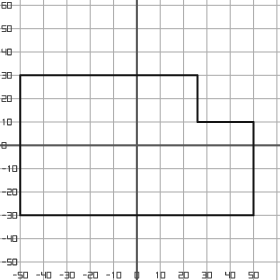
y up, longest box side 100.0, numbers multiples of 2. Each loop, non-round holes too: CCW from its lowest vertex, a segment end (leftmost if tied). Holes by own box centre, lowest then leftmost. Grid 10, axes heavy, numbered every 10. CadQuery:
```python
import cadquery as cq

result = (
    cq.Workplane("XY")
    .moveTo(-50.0, -30.0)
    .lineTo(50.0, -30.0)
    .lineTo(50.0, 10.0)
    .lineTo(26.0, 10.0)
    .lineTo(26.0, 30.0)
    .lineTo(-50.0, 30.0)
    .close()
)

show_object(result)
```